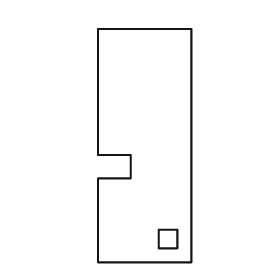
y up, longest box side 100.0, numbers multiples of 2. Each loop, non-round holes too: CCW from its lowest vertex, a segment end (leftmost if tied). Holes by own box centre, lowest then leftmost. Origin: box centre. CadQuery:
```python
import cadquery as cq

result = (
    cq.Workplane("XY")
    .moveTo(-20.0, -50.0)
    .lineTo(20.0, -50.0)
    .lineTo(20.0, 50.0)
    .lineTo(-20.0, 50.0)
    .lineTo(-20.0, -4.0)
    .lineTo(-6.0, -4.0)
    .lineTo(-6.0, -14.0)
    .lineTo(-20.0, -14.0)
    .close()
    .moveTo(6.0, -44.0)
    .lineTo(14.0, -44.0)
    .lineTo(14.0, -36.0)
    .lineTo(6.0, -36.0)
    .close()
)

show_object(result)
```